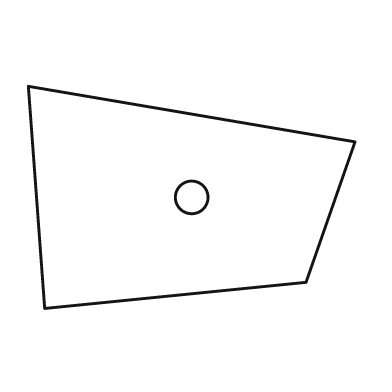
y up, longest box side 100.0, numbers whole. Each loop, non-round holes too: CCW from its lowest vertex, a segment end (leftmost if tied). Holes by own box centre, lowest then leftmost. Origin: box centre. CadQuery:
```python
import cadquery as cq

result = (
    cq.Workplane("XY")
    .moveTo(-45.0, -34.0)
    .lineTo(35.0, -26.0)
    .lineTo(50.0, 17.0)
    .lineTo(-50.0, 34.0)
    .close()
    .moveTo(0.0, 0.0)
    .circle(5.0)
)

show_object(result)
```